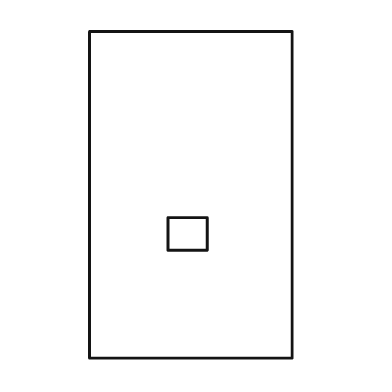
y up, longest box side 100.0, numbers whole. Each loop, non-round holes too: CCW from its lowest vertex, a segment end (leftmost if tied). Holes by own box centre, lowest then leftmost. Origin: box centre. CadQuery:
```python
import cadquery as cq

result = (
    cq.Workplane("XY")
    .moveTo(-31.0, -50.0)
    .lineTo(31.0, -50.0)
    .lineTo(31.0, 50.0)
    .lineTo(-31.0, 50.0)
    .close()
    .moveTo(-7.0, -17.0)
    .lineTo(5.0, -17.0)
    .lineTo(5.0, -7.0)
    .lineTo(-7.0, -7.0)
    .close()
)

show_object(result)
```